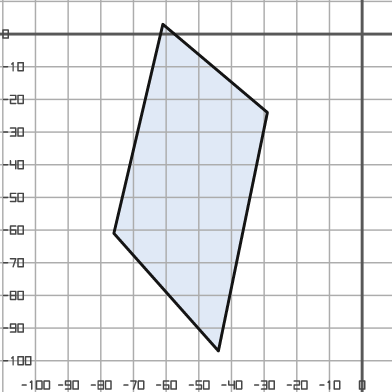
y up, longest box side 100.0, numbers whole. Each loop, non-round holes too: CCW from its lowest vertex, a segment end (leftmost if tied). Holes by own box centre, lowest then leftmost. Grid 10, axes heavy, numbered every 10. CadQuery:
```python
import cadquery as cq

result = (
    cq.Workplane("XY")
    .moveTo(-44.0, -97.0)
    .lineTo(-29.0, -24.0)
    .lineTo(-61.0, 3.0)
    .lineTo(-76.0, -61.0)
    .close()
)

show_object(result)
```